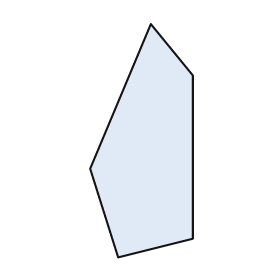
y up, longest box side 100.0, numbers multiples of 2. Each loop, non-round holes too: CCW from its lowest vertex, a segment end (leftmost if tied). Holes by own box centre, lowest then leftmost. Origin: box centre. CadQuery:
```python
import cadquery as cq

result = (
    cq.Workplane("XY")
    .moveTo(-10.0, -50.0)
    .lineTo(22.0, -42.0)
    .lineTo(22.0, 28.0)
    .lineTo(4.0, 50.0)
    .lineTo(-22.0, -12.0)
    .close()
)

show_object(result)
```